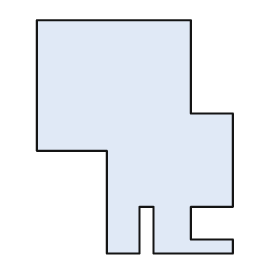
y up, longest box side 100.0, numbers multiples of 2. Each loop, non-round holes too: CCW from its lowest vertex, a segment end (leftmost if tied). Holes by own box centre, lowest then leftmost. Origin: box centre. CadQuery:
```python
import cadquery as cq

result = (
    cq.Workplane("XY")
    .moveTo(-12.0, -50.0)
    .lineTo(2.0, -50.0)
    .lineTo(2.0, -30.0)
    .lineTo(8.0, -30.0)
    .lineTo(8.0, -50.0)
    .lineTo(42.0, -50.0)
    .lineTo(42.0, -44.0)
    .lineTo(24.0, -44.0)
    .lineTo(24.0, -30.0)
    .lineTo(42.0, -30.0)
    .lineTo(42.0, 10.0)
    .lineTo(24.0, 10.0)
    .lineTo(24.0, 50.0)
    .lineTo(-42.0, 50.0)
    .lineTo(-42.0, -6.0)
    .lineTo(-12.0, -6.0)
    .close()
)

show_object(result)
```